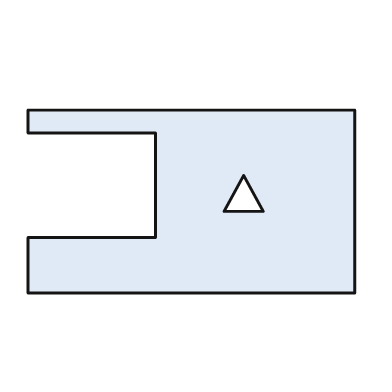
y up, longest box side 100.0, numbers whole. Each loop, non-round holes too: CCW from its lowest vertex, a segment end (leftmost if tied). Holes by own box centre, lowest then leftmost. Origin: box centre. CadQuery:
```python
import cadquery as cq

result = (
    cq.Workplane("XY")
    .moveTo(-50.0, -28.0)
    .lineTo(50.0, -28.0)
    .lineTo(50.0, 28.0)
    .lineTo(-50.0, 28.0)
    .lineTo(-50.0, 21.0)
    .lineTo(-11.0, 21.0)
    .lineTo(-11.0, -11.0)
    .lineTo(-50.0, -11.0)
    .close()
    .moveTo(10.0, -3.0)
    .lineTo(22.0, -3.0)
    .lineTo(16.0, 8.0)
    .close()
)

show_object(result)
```